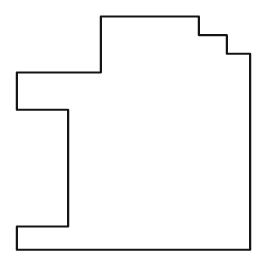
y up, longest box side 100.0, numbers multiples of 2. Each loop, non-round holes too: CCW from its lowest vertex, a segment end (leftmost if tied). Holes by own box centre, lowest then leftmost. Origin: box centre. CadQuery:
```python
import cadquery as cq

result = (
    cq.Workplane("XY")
    .moveTo(-50.0, -50.0)
    .lineTo(50.0, -50.0)
    .lineTo(50.0, 34.0)
    .lineTo(40.0, 34.0)
    .lineTo(40.0, 42.0)
    .lineTo(28.0, 42.0)
    .lineTo(28.0, 50.0)
    .lineTo(-14.0, 50.0)
    .lineTo(-14.0, 26.0)
    .lineTo(-50.0, 26.0)
    .lineTo(-50.0, 10.0)
    .lineTo(-28.0, 10.0)
    .lineTo(-28.0, -40.0)
    .lineTo(-50.0, -40.0)
    .close()
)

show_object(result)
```